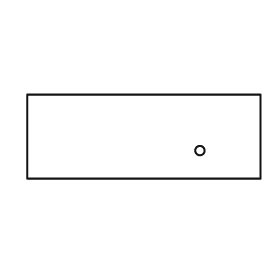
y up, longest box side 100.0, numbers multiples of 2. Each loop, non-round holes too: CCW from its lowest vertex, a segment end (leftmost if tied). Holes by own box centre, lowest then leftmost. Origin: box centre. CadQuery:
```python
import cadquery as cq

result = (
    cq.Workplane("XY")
    .moveTo(-50.0, -18.0)
    .lineTo(50.0, -18.0)
    .lineTo(50.0, 18.0)
    .lineTo(-50.0, 18.0)
    .close()
    .moveTo(24.0, -6.0)
    .circle(2.0)
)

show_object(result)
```